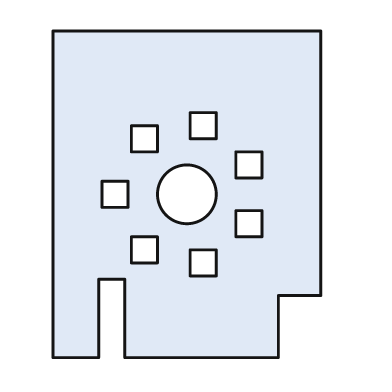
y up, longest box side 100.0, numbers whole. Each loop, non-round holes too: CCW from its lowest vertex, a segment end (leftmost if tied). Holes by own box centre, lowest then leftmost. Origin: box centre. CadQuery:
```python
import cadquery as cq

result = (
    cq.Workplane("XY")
    .moveTo(-41.0, -50.0)
    .lineTo(-27.0, -50.0)
    .lineTo(-27.0, -26.0)
    .lineTo(-19.0, -26.0)
    .lineTo(-19.0, -50.0)
    .lineTo(28.0, -50.0)
    .lineTo(28.0, -31.0)
    .lineTo(41.0, -31.0)
    .lineTo(41.0, 50.0)
    .lineTo(-41.0, 50.0)
    .close()
    .moveTo(1.0, -25.0)
    .lineTo(9.0, -25.0)
    .lineTo(9.0, -17.0)
    .lineTo(1.0, -17.0)
    .close()
    .moveTo(-17.0, -21.0)
    .lineTo(-9.0, -21.0)
    .lineTo(-9.0, -13.0)
    .lineTo(-17.0, -13.0)
    .close()
    .moveTo(15.0, -13.0)
    .lineTo(23.0, -13.0)
    .lineTo(23.0, -5.0)
    .lineTo(15.0, -5.0)
    .close()
    .moveTo(-26.0, -4.0)
    .lineTo(-18.0, -4.0)
    .lineTo(-18.0, 4.0)
    .lineTo(-26.0, 4.0)
    .close()
    .moveTo(0.0, 0.0)
    .circle(9.0)
    .moveTo(15.0, 5.0)
    .lineTo(23.0, 5.0)
    .lineTo(23.0, 13.0)
    .lineTo(15.0, 13.0)
    .close()
    .moveTo(-17.0, 13.0)
    .lineTo(-9.0, 13.0)
    .lineTo(-9.0, 21.0)
    .lineTo(-17.0, 21.0)
    .close()
    .moveTo(1.0, 17.0)
    .lineTo(9.0, 17.0)
    .lineTo(9.0, 25.0)
    .lineTo(1.0, 25.0)
    .close()
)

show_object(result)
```